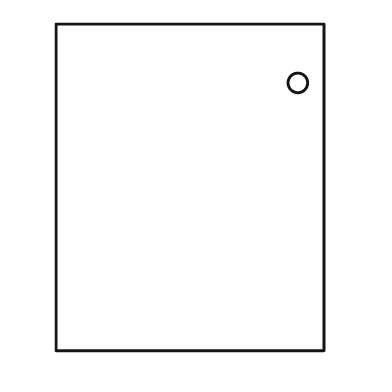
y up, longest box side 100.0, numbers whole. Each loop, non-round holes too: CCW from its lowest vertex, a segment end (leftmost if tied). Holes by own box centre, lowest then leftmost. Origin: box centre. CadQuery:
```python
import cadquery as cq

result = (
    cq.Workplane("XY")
    .moveTo(-41.0, -50.0)
    .lineTo(41.0, -50.0)
    .lineTo(41.0, 50.0)
    .lineTo(-41.0, 50.0)
    .close()
    .moveTo(33.0, 32.0)
    .circle(3.0)
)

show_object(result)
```